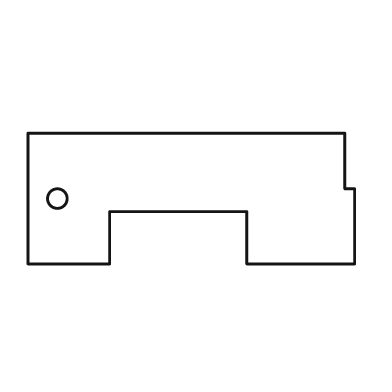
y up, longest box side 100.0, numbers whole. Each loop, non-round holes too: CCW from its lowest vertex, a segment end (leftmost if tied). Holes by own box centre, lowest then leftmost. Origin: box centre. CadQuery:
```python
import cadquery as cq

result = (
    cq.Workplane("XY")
    .moveTo(-50.0, -20.0)
    .lineTo(-25.0, -20.0)
    .lineTo(-25.0, -4.0)
    .lineTo(17.0, -4.0)
    .lineTo(17.0, -20.0)
    .lineTo(50.0, -20.0)
    .lineTo(50.0, 3.0)
    .lineTo(47.0, 3.0)
    .lineTo(47.0, 20.0)
    .lineTo(-50.0, 20.0)
    .close()
    .moveTo(-41.0, 0.0)
    .circle(3.0)
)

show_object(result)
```